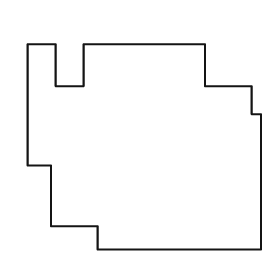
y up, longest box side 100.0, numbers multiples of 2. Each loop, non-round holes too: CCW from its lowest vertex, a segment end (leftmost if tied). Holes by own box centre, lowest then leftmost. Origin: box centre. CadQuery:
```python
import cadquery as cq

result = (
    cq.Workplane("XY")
    .moveTo(-20.0, -44.0)
    .lineTo(50.0, -44.0)
    .lineTo(50.0, 14.0)
    .lineTo(46.0, 14.0)
    .lineTo(46.0, 26.0)
    .lineTo(26.0, 26.0)
    .lineTo(26.0, 44.0)
    .lineTo(-26.0, 44.0)
    .lineTo(-26.0, 26.0)
    .lineTo(-38.0, 26.0)
    .lineTo(-38.0, 44.0)
    .lineTo(-50.0, 44.0)
    .lineTo(-50.0, -8.0)
    .lineTo(-40.0, -8.0)
    .lineTo(-40.0, -34.0)
    .lineTo(-20.0, -34.0)
    .close()
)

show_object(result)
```